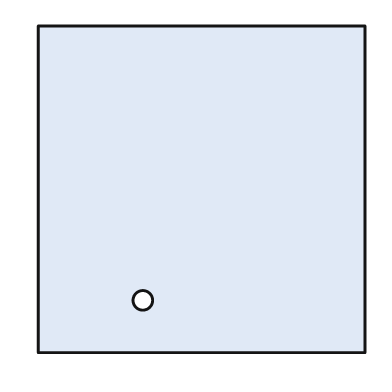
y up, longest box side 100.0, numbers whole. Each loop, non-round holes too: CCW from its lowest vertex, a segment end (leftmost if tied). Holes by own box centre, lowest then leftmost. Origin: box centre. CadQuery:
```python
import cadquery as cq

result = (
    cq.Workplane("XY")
    .moveTo(-50.0, -50.0)
    .lineTo(50.0, -50.0)
    .lineTo(50.0, 50.0)
    .lineTo(-50.0, 50.0)
    .close()
    .moveTo(-18.0, -34.0)
    .circle(3.0)
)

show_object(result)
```